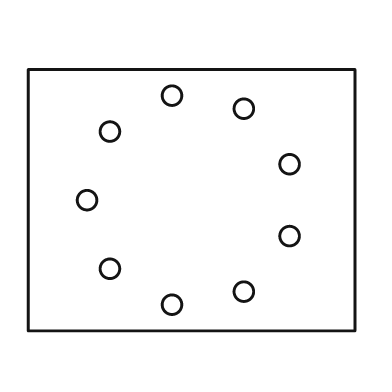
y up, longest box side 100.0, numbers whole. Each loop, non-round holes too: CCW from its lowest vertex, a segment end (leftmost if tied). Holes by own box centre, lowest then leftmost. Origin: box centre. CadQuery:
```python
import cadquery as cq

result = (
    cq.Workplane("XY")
    .moveTo(-50.0, -40.0)
    .lineTo(50.0, -40.0)
    .lineTo(50.0, 40.0)
    .lineTo(-50.0, 40.0)
    .close()
    .moveTo(-6.0, -32.0)
    .circle(3.0)
    .moveTo(16.0, -28.0)
    .circle(3.0)
    .moveTo(-25.0, -21.0)
    .circle(3.0)
    .moveTo(30.0, -11.0)
    .circle(3.0)
    .moveTo(-32.0, 0.0)
    .circle(3.0)
    .moveTo(30.0, 11.0)
    .circle(3.0)
    .moveTo(-25.0, 21.0)
    .circle(3.0)
    .moveTo(16.0, 28.0)
    .circle(3.0)
    .moveTo(-6.0, 32.0)
    .circle(3.0)
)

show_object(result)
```